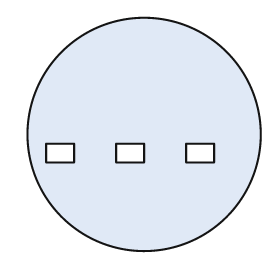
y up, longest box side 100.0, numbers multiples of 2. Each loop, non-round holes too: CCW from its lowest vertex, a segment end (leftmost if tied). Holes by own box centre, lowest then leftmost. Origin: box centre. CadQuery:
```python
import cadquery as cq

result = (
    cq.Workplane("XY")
    .moveTo(0.0, 0.0)
    .circle(50.0)
    .moveTo(-42.0, -12.0)
    .lineTo(-30.0, -12.0)
    .lineTo(-30.0, -4.0)
    .lineTo(-42.0, -4.0)
    .close()
    .moveTo(-12.0, -12.0)
    .lineTo(0.0, -12.0)
    .lineTo(0.0, -4.0)
    .lineTo(-12.0, -4.0)
    .close()
    .moveTo(18.0, -12.0)
    .lineTo(30.0, -12.0)
    .lineTo(30.0, -4.0)
    .lineTo(18.0, -4.0)
    .close()
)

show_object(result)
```